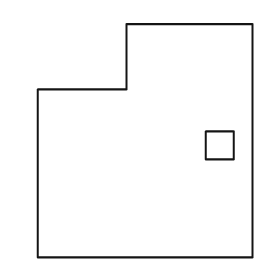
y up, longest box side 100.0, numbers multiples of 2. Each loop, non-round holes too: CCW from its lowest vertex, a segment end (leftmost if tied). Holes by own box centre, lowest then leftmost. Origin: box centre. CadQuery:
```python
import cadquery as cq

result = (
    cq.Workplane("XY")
    .moveTo(-46.0, -50.0)
    .lineTo(46.0, -50.0)
    .lineTo(46.0, 50.0)
    .lineTo(-8.0, 50.0)
    .lineTo(-8.0, 22.0)
    .lineTo(-46.0, 22.0)
    .close()
    .moveTo(26.0, -8.0)
    .lineTo(38.0, -8.0)
    .lineTo(38.0, 4.0)
    .lineTo(26.0, 4.0)
    .close()
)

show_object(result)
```